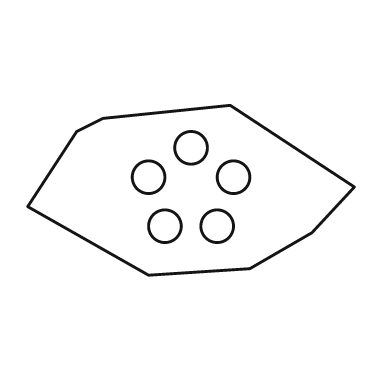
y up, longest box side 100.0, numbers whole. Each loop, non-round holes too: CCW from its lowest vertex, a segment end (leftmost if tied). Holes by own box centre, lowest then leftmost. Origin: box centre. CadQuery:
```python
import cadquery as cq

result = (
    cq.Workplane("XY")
    .moveTo(-13.0, -26.0)
    .lineTo(18.0, -24.0)
    .lineTo(37.0, -13.0)
    .lineTo(50.0, 1.0)
    .lineTo(12.0, 26.0)
    .lineTo(-27.0, 22.0)
    .lineTo(-35.0, 18.0)
    .lineTo(-50.0, -5.0)
    .close()
    .moveTo(-8.0, -11.0)
    .circle(5.0)
    .moveTo(8.0, -11.0)
    .circle(5.0)
    .moveTo(-13.0, 4.0)
    .circle(5.0)
    .moveTo(13.0, 4.0)
    .circle(5.0)
    .moveTo(0.0, 13.0)
    .circle(5.0)
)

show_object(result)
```